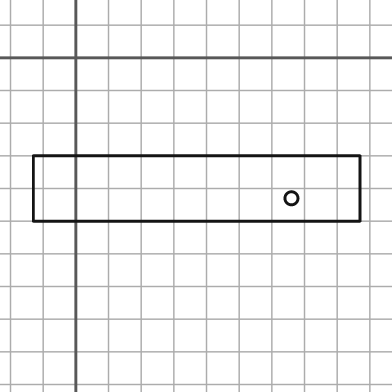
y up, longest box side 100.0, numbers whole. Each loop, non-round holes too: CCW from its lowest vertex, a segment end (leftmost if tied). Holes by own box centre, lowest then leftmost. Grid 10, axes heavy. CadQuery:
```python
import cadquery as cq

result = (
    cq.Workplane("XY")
    .moveTo(-13.0, -50.0)
    .lineTo(87.0, -50.0)
    .lineTo(87.0, -30.0)
    .lineTo(-13.0, -30.0)
    .close()
    .moveTo(66.0, -43.0)
    .circle(2.0)
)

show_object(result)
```